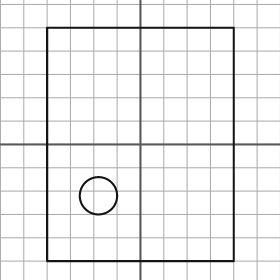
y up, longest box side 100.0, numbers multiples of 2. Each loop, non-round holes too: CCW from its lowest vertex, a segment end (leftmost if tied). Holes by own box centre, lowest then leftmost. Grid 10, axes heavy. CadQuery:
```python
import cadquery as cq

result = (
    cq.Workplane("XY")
    .moveTo(-40.0, -50.0)
    .lineTo(40.0, -50.0)
    .lineTo(40.0, 50.0)
    .lineTo(-40.0, 50.0)
    .close()
    .moveTo(-18.0, -22.0)
    .circle(8.0)
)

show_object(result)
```